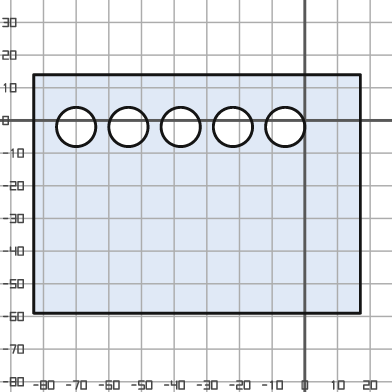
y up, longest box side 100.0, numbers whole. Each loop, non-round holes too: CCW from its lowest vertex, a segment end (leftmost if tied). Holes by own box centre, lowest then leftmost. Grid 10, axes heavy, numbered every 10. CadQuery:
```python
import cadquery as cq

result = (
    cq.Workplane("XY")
    .moveTo(-83.0, -59.0)
    .lineTo(17.0, -59.0)
    .lineTo(17.0, 14.0)
    .lineTo(-83.0, 14.0)
    .close()
    .moveTo(-70.0, -2.0)
    .circle(6.0)
    .moveTo(-54.0, -2.0)
    .circle(6.0)
    .moveTo(-38.0, -2.0)
    .circle(6.0)
    .moveTo(-22.0, -2.0)
    .circle(6.0)
    .moveTo(-6.0, -2.0)
    .circle(6.0)
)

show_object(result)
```